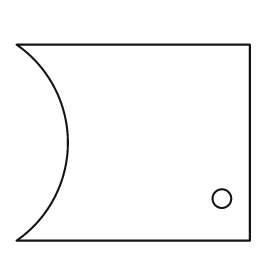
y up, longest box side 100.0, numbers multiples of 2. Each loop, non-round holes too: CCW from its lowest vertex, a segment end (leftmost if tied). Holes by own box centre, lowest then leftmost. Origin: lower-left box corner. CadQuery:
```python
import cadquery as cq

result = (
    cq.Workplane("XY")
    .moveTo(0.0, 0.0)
    .lineTo(100.0, 0.0)
    .lineTo(100.0, 84.0)
    .lineTo(0.0, 84.0)
    .threePointArc((22.0, 42.0), (0.0, 0.0))
    .close()
    .moveTo(88.0, 18.0)
    .circle(4.0)
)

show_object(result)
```